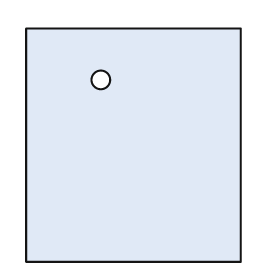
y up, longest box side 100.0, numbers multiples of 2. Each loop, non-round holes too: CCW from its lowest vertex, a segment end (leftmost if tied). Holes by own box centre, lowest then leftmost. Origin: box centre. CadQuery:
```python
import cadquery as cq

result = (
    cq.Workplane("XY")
    .moveTo(-46.0, -50.0)
    .lineTo(46.0, -50.0)
    .lineTo(46.0, 50.0)
    .lineTo(-46.0, 50.0)
    .close()
    .moveTo(-14.0, 28.0)
    .circle(4.0)
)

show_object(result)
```